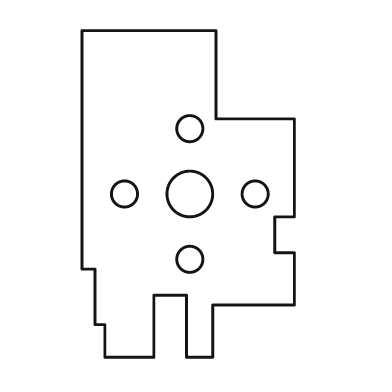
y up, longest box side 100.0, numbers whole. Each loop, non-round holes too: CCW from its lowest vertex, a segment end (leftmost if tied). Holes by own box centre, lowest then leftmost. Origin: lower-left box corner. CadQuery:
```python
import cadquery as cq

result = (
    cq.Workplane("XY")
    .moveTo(7.0, 0.0)
    .lineTo(22.0, 0.0)
    .lineTo(22.0, 19.0)
    .lineTo(32.0, 19.0)
    .lineTo(32.0, 0.0)
    .lineTo(40.0, 0.0)
    .lineTo(40.0, 16.0)
    .lineTo(65.0, 16.0)
    .lineTo(65.0, 32.0)
    .lineTo(59.0, 32.0)
    .lineTo(59.0, 43.0)
    .lineTo(65.0, 43.0)
    .lineTo(65.0, 73.0)
    .lineTo(41.0, 73.0)
    .lineTo(41.0, 100.0)
    .lineTo(0.0, 100.0)
    .lineTo(0.0, 27.0)
    .lineTo(4.0, 27.0)
    .lineTo(4.0, 10.0)
    .lineTo(7.0, 10.0)
    .close()
    .moveTo(33.0, 30.0)
    .circle(4.0)
    .moveTo(13.0, 50.0)
    .circle(4.0)
    .moveTo(33.0, 50.0)
    .circle(7.0)
    .moveTo(53.0, 50.0)
    .circle(4.0)
    .moveTo(33.0, 70.0)
    .circle(4.0)
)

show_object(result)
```